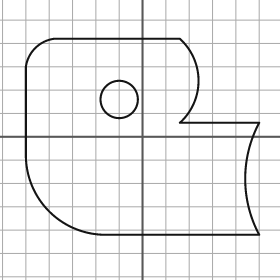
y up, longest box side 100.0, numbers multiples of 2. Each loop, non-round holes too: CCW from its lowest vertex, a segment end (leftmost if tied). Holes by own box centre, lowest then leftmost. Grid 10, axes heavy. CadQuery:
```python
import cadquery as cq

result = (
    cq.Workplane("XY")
    .moveTo(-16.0, -42.0)
    .lineTo(50.0, -42.0)
    .threePointArc((44.0, -18.0), (50.0, 6.0))
    .lineTo(16.0, 6.0)
    .threePointArc((24.0, 24.0), (16.0, 42.0))
    .lineTo(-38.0, 42.0)
    .threePointArc((-46.0, 38.0), (-50.0, 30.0))
    .lineTo(-50.0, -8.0)
    .threePointArc((-40.0, -32.0), (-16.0, -42.0))
    .close()
    .moveTo(-10.0, 16.0)
    .circle(8.0)
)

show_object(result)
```